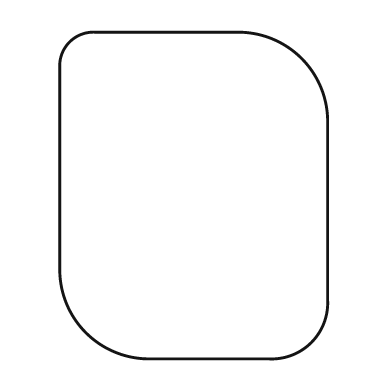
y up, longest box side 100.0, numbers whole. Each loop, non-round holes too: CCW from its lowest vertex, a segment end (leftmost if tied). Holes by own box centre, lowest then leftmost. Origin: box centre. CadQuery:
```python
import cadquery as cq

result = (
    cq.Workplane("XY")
    .moveTo(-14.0, -50.0)
    .lineTo(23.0, -50.0)
    .threePointArc((36.0, -45.0), (41.0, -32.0))
    .lineTo(41.0, 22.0)
    .threePointArc((33.0, 42.0), (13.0, 50.0))
    .lineTo(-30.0, 50.0)
    .threePointArc((-38.0, 47.0), (-41.0, 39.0))
    .lineTo(-41.0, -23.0)
    .threePointArc((-33.0, -42.0), (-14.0, -50.0))
    .close()
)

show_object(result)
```